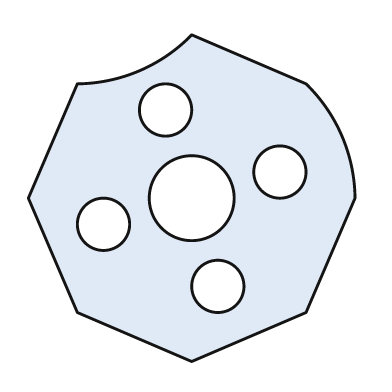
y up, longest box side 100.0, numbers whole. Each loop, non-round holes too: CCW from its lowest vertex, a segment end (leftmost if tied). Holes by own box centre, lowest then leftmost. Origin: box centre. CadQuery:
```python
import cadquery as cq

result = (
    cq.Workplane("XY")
    .moveTo(0.0, -50.0)
    .lineTo(35.0, -35.0)
    .lineTo(50.0, 0.0)
    .threePointArc((46.0, 19.0), (35.0, 35.0))
    .lineTo(0.0, 50.0)
    .threePointArc((-16.0, 39.0), (-35.0, 35.0))
    .lineTo(-50.0, 0.0)
    .lineTo(-35.0, -35.0)
    .close()
    .moveTo(8.0, -27.0)
    .circle(8.0)
    .moveTo(-27.0, -8.0)
    .circle(8.0)
    .moveTo(0.0, 0.0)
    .circle(13.0)
    .moveTo(27.0, 8.0)
    .circle(8.0)
    .moveTo(-8.0, 27.0)
    .circle(8.0)
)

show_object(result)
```